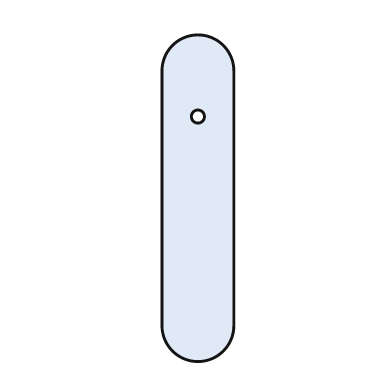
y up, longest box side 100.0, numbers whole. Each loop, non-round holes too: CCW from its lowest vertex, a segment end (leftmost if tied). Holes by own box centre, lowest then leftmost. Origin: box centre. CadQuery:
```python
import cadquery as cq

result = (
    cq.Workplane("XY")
    .moveTo(-11.0, -39.0)
    .threePointArc((0.0, -50.0), (11.0, -39.0))
    .lineTo(11.0, 39.0)
    .threePointArc((0.0, 50.0), (-11.0, 39.0))
    .close()
    .moveTo(0.0, 25.0)
    .circle(2.0)
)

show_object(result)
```